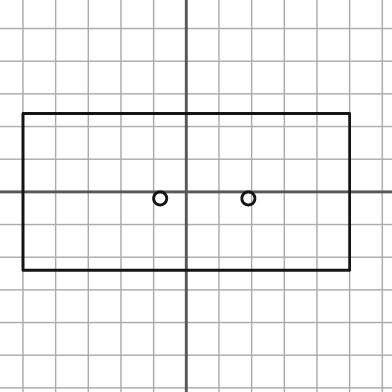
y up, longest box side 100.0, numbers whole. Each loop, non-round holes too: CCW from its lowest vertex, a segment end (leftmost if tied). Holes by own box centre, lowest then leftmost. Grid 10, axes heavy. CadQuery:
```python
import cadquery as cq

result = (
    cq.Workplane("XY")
    .moveTo(-50.0, -24.0)
    .lineTo(50.0, -24.0)
    .lineTo(50.0, 24.0)
    .lineTo(-50.0, 24.0)
    .close()
    .moveTo(-8.0, -2.0)
    .circle(2.0)
    .moveTo(19.0, -2.0)
    .circle(2.0)
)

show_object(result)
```